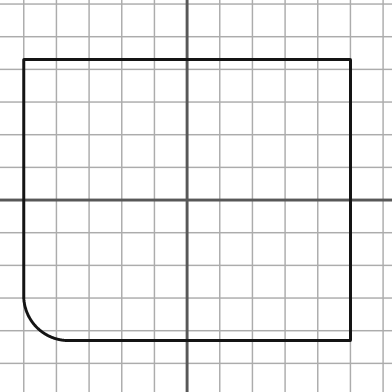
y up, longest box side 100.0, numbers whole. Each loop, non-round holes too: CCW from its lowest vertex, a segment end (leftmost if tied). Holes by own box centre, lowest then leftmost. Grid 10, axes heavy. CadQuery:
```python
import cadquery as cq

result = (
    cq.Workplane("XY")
    .moveTo(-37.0, -43.0)
    .lineTo(50.0, -43.0)
    .lineTo(50.0, 43.0)
    .lineTo(-50.0, 43.0)
    .lineTo(-50.0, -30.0)
    .threePointArc((-46.0, -39.0), (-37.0, -43.0))
    .close()
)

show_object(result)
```